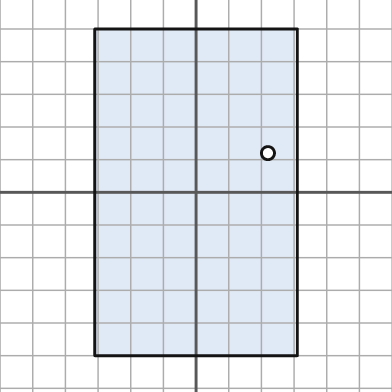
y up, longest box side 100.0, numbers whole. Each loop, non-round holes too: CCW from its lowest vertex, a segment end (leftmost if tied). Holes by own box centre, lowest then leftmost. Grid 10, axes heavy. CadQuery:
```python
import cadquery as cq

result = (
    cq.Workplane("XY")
    .moveTo(-31.0, -50.0)
    .lineTo(31.0, -50.0)
    .lineTo(31.0, 50.0)
    .lineTo(-31.0, 50.0)
    .close()
    .moveTo(22.0, 12.0)
    .circle(2.0)
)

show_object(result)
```